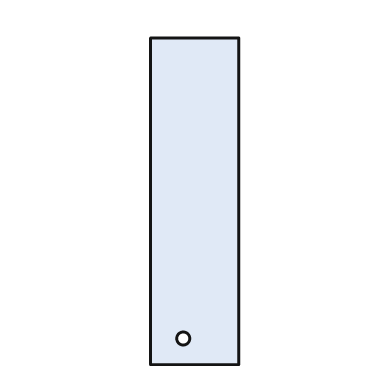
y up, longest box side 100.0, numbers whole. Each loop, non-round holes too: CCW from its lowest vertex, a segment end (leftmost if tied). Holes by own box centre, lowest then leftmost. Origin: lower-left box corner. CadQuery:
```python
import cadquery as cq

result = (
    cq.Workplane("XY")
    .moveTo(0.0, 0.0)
    .lineTo(27.0, 0.0)
    .lineTo(27.0, 100.0)
    .lineTo(0.0, 100.0)
    .close()
    .moveTo(10.0, 8.0)
    .circle(2.0)
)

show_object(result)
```